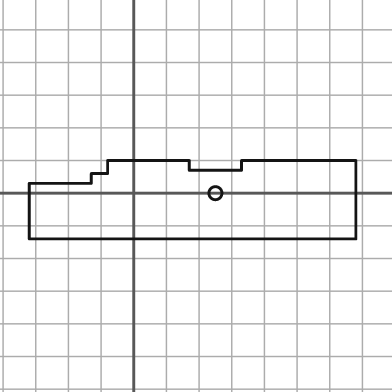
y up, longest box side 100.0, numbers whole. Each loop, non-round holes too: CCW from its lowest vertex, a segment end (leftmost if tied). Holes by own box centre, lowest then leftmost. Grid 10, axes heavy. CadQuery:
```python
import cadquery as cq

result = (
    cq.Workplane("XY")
    .moveTo(-32.0, -14.0)
    .lineTo(68.0, -14.0)
    .lineTo(68.0, 10.0)
    .lineTo(33.0, 10.0)
    .lineTo(33.0, 7.0)
    .lineTo(17.0, 7.0)
    .lineTo(17.0, 10.0)
    .lineTo(-8.0, 10.0)
    .lineTo(-8.0, 6.0)
    .lineTo(-13.0, 6.0)
    .lineTo(-13.0, 3.0)
    .lineTo(-32.0, 3.0)
    .close()
    .moveTo(25.0, 0.0)
    .circle(2.0)
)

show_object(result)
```